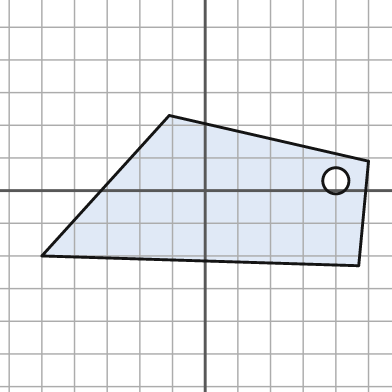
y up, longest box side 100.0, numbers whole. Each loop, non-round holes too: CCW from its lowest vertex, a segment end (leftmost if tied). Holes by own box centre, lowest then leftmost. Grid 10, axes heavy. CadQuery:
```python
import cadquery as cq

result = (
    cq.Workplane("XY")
    .moveTo(47.0, -23.0)
    .lineTo(50.0, 9.0)
    .lineTo(-11.0, 23.0)
    .lineTo(-50.0, -20.0)
    .close()
    .moveTo(40.0, 3.0)
    .circle(4.0)
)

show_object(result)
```